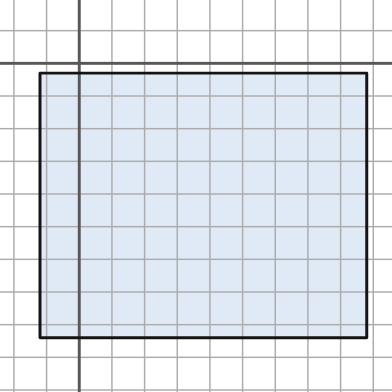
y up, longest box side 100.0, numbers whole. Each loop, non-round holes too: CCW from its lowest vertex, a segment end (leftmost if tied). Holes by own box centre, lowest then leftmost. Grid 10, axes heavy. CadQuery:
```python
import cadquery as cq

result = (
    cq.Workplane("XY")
    .moveTo(-12.0, -84.0)
    .lineTo(88.0, -84.0)
    .lineTo(88.0, -3.0)
    .lineTo(-12.0, -3.0)
    .close()
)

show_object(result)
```